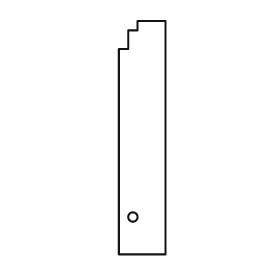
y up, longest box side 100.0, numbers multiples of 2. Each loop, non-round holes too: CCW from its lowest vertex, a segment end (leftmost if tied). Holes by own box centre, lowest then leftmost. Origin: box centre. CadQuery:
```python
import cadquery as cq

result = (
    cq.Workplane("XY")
    .moveTo(-10.0, -50.0)
    .lineTo(10.0, -50.0)
    .lineTo(10.0, 50.0)
    .lineTo(-2.0, 50.0)
    .lineTo(-2.0, 46.0)
    .lineTo(-6.0, 46.0)
    .lineTo(-6.0, 38.0)
    .lineTo(-10.0, 38.0)
    .close()
    .moveTo(-4.0, -34.0)
    .circle(2.0)
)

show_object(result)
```